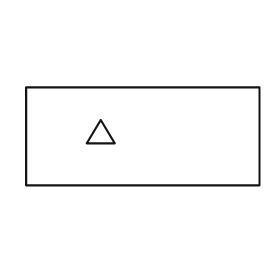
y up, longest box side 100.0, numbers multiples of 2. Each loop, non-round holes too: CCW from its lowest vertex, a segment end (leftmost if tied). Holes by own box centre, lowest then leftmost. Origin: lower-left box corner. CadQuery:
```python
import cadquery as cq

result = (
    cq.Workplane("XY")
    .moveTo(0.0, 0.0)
    .lineTo(100.0, 0.0)
    .lineTo(100.0, 42.0)
    .lineTo(0.0, 42.0)
    .close()
    .moveTo(26.0, 18.0)
    .lineTo(38.0, 18.0)
    .lineTo(32.0, 28.0)
    .close()
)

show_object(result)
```